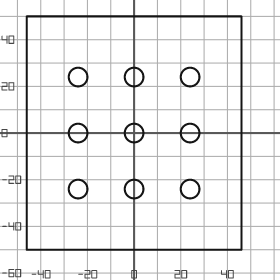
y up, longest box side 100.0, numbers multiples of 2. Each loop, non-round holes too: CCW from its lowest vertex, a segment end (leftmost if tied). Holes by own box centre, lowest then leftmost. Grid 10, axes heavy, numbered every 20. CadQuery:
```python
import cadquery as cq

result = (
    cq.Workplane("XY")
    .moveTo(-46.0, -50.0)
    .lineTo(46.0, -50.0)
    .lineTo(46.0, 50.0)
    .lineTo(-46.0, 50.0)
    .close()
    .moveTo(-24.0, -24.0)
    .circle(4.0)
    .moveTo(0.0, -24.0)
    .circle(4.0)
    .moveTo(24.0, -24.0)
    .circle(4.0)
    .moveTo(-24.0, 0.0)
    .circle(4.0)
    .moveTo(0.0, 0.0)
    .circle(4.0)
    .moveTo(24.0, 0.0)
    .circle(4.0)
    .moveTo(-24.0, 24.0)
    .circle(4.0)
    .moveTo(0.0, 24.0)
    .circle(4.0)
    .moveTo(24.0, 24.0)
    .circle(4.0)
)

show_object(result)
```